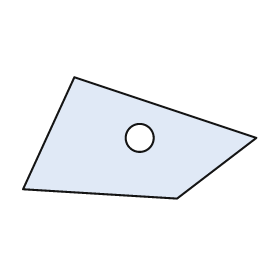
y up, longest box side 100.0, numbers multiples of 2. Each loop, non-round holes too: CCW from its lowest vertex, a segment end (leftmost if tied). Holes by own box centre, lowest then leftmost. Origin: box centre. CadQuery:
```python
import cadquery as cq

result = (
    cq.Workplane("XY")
    .moveTo(16.0, -26.0)
    .lineTo(50.0, 0.0)
    .lineTo(-28.0, 26.0)
    .lineTo(-50.0, -22.0)
    .close()
    .moveTo(0.0, 0.0)
    .circle(6.0)
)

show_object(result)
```